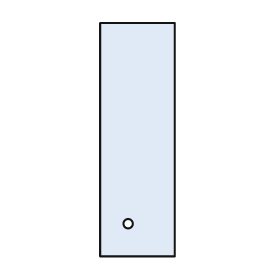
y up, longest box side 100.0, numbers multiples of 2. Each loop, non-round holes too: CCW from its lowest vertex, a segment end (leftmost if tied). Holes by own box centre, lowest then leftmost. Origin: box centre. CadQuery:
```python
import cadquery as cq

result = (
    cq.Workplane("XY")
    .moveTo(-16.0, -50.0)
    .lineTo(16.0, -50.0)
    .lineTo(16.0, 50.0)
    .lineTo(-16.0, 50.0)
    .close()
    .moveTo(-4.0, -36.0)
    .circle(2.0)
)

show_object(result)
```